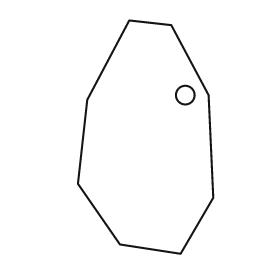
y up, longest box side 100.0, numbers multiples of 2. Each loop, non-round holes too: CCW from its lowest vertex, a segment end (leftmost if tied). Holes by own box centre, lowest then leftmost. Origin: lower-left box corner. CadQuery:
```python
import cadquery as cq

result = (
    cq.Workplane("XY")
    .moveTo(44.0, 0.0)
    .lineTo(58.0, 24.0)
    .lineTo(56.0, 68.0)
    .lineTo(40.0, 98.0)
    .lineTo(22.0, 100.0)
    .lineTo(4.0, 66.0)
    .lineTo(0.0, 30.0)
    .lineTo(18.0, 4.0)
    .close()
    .moveTo(46.0, 68.0)
    .circle(4.0)
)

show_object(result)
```